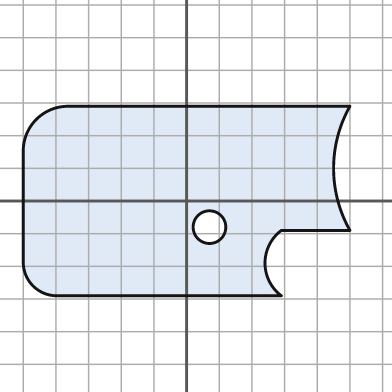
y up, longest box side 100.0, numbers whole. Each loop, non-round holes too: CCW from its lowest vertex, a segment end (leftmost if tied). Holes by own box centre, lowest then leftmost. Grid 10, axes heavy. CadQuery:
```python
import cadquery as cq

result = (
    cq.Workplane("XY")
    .moveTo(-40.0, -29.0)
    .lineTo(29.0, -29.0)
    .threePointArc((24.0, -19.0), (29.0, -9.0))
    .lineTo(50.0, -9.0)
    .threePointArc((45.0, 10.0), (50.0, 29.0))
    .lineTo(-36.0, 29.0)
    .threePointArc((-46.0, 25.0), (-50.0, 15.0))
    .lineTo(-50.0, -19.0)
    .threePointArc((-47.0, -26.0), (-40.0, -29.0))
    .close()
    .moveTo(7.0, -8.0)
    .circle(5.0)
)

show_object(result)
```